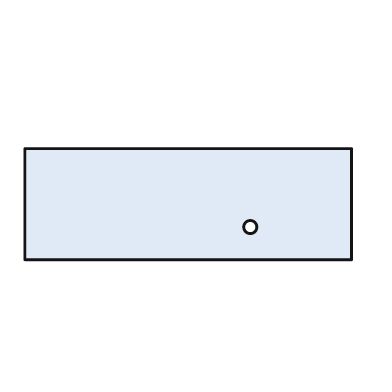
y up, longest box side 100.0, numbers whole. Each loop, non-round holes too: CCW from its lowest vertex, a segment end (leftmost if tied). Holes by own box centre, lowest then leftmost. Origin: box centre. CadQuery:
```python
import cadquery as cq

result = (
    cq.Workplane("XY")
    .moveTo(-50.0, -17.0)
    .lineTo(50.0, -17.0)
    .lineTo(50.0, 17.0)
    .lineTo(-50.0, 17.0)
    .close()
    .moveTo(19.0, -7.0)
    .circle(2.0)
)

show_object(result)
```